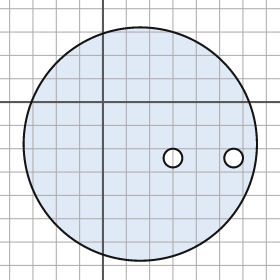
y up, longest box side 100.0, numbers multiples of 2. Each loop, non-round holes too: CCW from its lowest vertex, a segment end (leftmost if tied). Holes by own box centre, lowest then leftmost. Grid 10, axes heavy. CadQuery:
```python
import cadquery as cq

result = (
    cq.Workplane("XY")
    .moveTo(16.0, -18.0)
    .circle(50.0)
    .moveTo(30.0, -24.0)
    .circle(4.0)
    .moveTo(56.0, -24.0)
    .circle(4.0)
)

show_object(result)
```